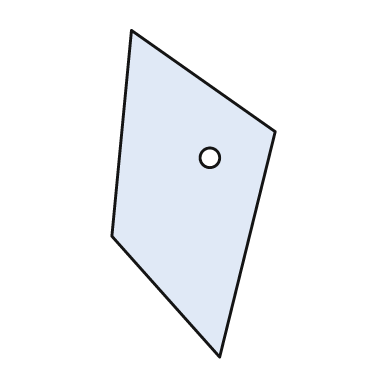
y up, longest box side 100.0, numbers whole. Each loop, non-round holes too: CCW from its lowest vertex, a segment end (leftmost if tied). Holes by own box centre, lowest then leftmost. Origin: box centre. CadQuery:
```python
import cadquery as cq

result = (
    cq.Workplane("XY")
    .moveTo(8.0, -50.0)
    .lineTo(25.0, 19.0)
    .lineTo(-19.0, 50.0)
    .lineTo(-25.0, -13.0)
    .close()
    .moveTo(5.0, 11.0)
    .circle(3.0)
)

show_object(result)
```